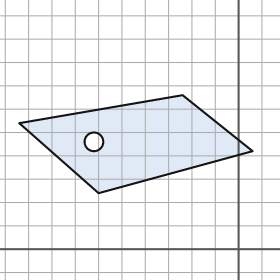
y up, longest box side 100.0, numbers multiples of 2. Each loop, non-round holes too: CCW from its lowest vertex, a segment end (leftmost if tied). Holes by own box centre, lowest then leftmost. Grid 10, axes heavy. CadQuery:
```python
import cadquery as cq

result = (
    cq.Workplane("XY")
    .moveTo(-60.0, 24.0)
    .lineTo(6.0, 42.0)
    .lineTo(-24.0, 66.0)
    .lineTo(-94.0, 54.0)
    .close()
    .moveTo(-62.0, 46.0)
    .circle(4.0)
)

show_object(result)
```